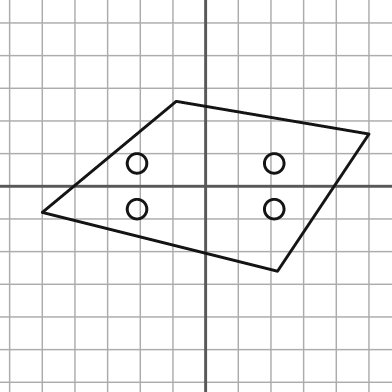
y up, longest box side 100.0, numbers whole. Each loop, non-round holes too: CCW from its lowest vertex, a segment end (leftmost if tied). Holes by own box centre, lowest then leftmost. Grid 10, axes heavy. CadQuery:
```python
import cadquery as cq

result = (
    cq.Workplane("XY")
    .moveTo(22.0, -26.0)
    .lineTo(50.0, 16.0)
    .lineTo(-9.0, 26.0)
    .lineTo(-50.0, -8.0)
    .close()
    .moveTo(-21.0, -7.0)
    .circle(3.0)
    .moveTo(21.0, -7.0)
    .circle(3.0)
    .moveTo(-21.0, 7.0)
    .circle(3.0)
    .moveTo(21.0, 7.0)
    .circle(3.0)
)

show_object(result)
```